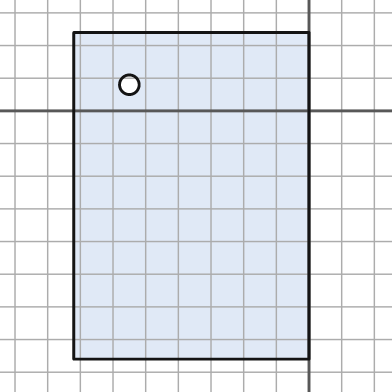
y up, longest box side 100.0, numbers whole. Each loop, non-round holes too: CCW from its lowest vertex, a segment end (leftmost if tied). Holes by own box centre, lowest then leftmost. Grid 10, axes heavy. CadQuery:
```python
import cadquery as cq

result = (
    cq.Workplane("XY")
    .moveTo(-72.0, -76.0)
    .lineTo(0.0, -76.0)
    .lineTo(0.0, 24.0)
    .lineTo(-72.0, 24.0)
    .close()
    .moveTo(-55.0, 8.0)
    .circle(3.0)
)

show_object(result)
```